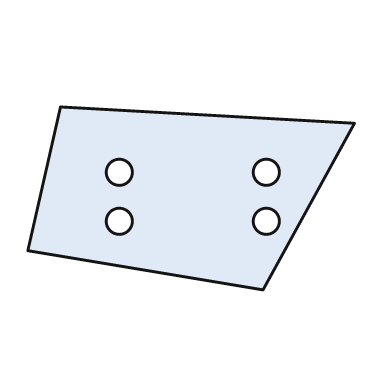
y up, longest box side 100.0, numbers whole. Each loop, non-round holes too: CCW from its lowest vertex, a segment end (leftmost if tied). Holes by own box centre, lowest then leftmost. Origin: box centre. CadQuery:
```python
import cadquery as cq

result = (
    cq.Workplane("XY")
    .moveTo(22.0, -28.0)
    .lineTo(50.0, 23.0)
    .lineTo(-40.0, 28.0)
    .lineTo(-50.0, -16.0)
    .close()
    .moveTo(-22.0, -7.0)
    .circle(4.0)
    .moveTo(23.0, -7.0)
    .circle(4.0)
    .moveTo(-22.0, 8.0)
    .circle(4.0)
    .moveTo(23.0, 8.0)
    .circle(4.0)
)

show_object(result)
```